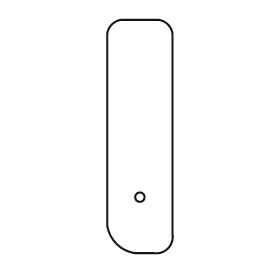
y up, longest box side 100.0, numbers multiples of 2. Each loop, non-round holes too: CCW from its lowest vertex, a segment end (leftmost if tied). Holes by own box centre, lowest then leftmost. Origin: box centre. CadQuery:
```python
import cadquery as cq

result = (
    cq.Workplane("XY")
    .moveTo(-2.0, -50.0)
    .lineTo(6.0, -50.0)
    .threePointArc((12.0, -48.0), (14.0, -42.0))
    .lineTo(14.0, 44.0)
    .threePointArc((12.0, 48.0), (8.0, 50.0))
    .lineTo(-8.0, 50.0)
    .threePointArc((-12.0, 48.0), (-14.0, 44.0))
    .lineTo(-14.0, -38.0)
    .threePointArc((-10.0, -46.0), (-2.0, -50.0))
    .close()
    .moveTo(0.0, -26.0)
    .circle(2.0)
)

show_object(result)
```